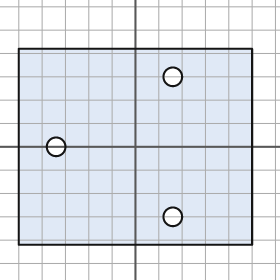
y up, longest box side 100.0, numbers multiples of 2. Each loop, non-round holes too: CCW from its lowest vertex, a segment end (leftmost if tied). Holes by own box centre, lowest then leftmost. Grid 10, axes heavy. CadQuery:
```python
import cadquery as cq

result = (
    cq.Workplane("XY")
    .moveTo(-50.0, -42.0)
    .lineTo(50.0, -42.0)
    .lineTo(50.0, 42.0)
    .lineTo(-50.0, 42.0)
    .close()
    .moveTo(16.0, -30.0)
    .circle(4.0)
    .moveTo(-34.0, 0.0)
    .circle(4.0)
    .moveTo(16.0, 30.0)
    .circle(4.0)
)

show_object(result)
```